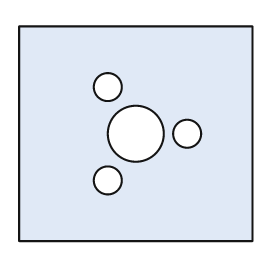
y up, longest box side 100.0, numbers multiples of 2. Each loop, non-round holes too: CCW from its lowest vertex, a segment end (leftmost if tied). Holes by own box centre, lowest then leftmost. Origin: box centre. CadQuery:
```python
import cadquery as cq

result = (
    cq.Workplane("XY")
    .moveTo(-50.0, -46.0)
    .lineTo(50.0, -46.0)
    .lineTo(50.0, 46.0)
    .lineTo(-50.0, 46.0)
    .close()
    .moveTo(-12.0, -20.0)
    .circle(6.0)
    .moveTo(0.0, 0.0)
    .circle(12.0)
    .moveTo(22.0, 0.0)
    .circle(6.0)
    .moveTo(-12.0, 20.0)
    .circle(6.0)
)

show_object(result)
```